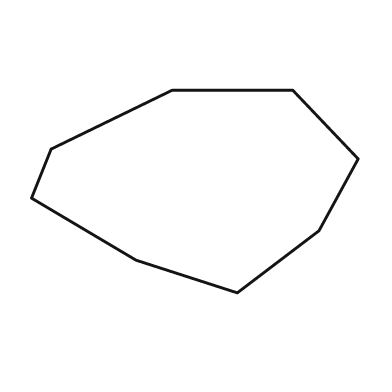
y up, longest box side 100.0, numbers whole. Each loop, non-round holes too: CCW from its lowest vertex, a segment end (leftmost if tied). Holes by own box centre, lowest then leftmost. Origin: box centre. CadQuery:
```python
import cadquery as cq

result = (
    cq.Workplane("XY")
    .moveTo(13.0, -31.0)
    .lineTo(38.0, -12.0)
    .lineTo(50.0, 10.0)
    .lineTo(30.0, 31.0)
    .lineTo(-7.0, 31.0)
    .lineTo(-44.0, 13.0)
    .lineTo(-50.0, -2.0)
    .lineTo(-18.0, -21.0)
    .close()
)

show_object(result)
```